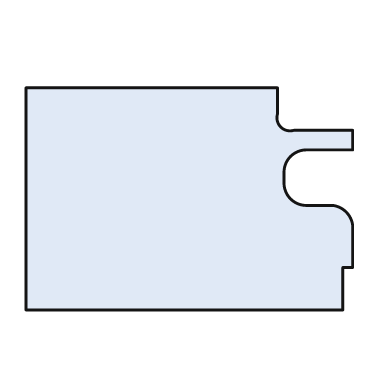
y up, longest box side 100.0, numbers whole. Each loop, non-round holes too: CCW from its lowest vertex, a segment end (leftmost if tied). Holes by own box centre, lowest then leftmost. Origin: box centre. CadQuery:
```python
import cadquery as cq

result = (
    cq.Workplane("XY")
    .moveTo(-50.0, -34.0)
    .lineTo(47.0, -34.0)
    .lineTo(47.0, -21.0)
    .lineTo(50.0, -21.0)
    .lineTo(50.0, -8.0)
    .threePointArc((48.0, -4.0), (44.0, -2.0))
    .lineTo(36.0, -2.0)
    .threePointArc((31.0, 0.0), (29.0, 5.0))
    .lineTo(29.0, 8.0)
    .threePointArc((31.0, 13.0), (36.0, 15.0))
    .lineTo(50.0, 15.0)
    .lineTo(50.0, 21.0)
    .lineTo(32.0, 21.0)
    .threePointArc((28.0, 22.0), (27.0, 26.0))
    .lineTo(27.0, 34.0)
    .lineTo(-50.0, 34.0)
    .close()
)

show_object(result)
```